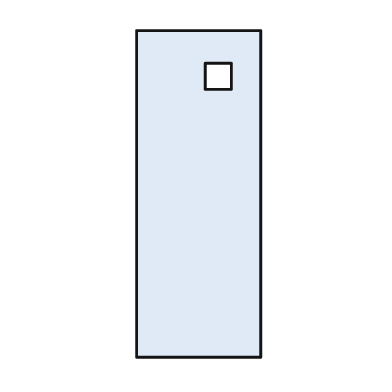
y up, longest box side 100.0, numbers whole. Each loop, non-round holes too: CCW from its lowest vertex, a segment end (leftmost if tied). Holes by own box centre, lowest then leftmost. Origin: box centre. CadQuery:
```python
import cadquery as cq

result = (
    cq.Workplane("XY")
    .moveTo(-19.0, -50.0)
    .lineTo(19.0, -50.0)
    .lineTo(19.0, 50.0)
    .lineTo(-19.0, 50.0)
    .close()
    .moveTo(2.0, 32.0)
    .lineTo(10.0, 32.0)
    .lineTo(10.0, 40.0)
    .lineTo(2.0, 40.0)
    .close()
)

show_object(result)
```